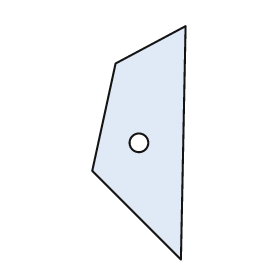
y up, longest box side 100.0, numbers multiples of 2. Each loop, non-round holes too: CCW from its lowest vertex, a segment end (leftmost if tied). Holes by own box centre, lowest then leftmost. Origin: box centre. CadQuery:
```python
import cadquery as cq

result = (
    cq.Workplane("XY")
    .moveTo(18.0, -50.0)
    .lineTo(20.0, 50.0)
    .lineTo(-10.0, 34.0)
    .lineTo(-20.0, -12.0)
    .close()
    .moveTo(0.0, 0.0)
    .circle(4.0)
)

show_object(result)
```